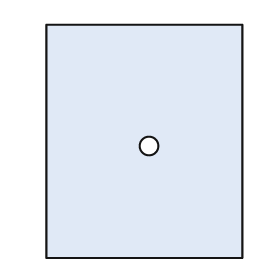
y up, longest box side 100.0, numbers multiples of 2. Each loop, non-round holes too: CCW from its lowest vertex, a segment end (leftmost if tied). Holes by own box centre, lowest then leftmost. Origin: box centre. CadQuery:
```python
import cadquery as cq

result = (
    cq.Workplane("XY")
    .moveTo(-42.0, -50.0)
    .lineTo(42.0, -50.0)
    .lineTo(42.0, 50.0)
    .lineTo(-42.0, 50.0)
    .close()
    .moveTo(2.0, -2.0)
    .circle(4.0)
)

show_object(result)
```